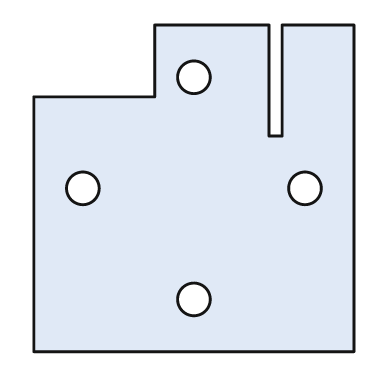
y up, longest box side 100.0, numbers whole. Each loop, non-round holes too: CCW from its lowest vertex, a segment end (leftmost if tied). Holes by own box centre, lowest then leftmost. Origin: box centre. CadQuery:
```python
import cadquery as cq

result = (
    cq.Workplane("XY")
    .moveTo(-49.0, -50.0)
    .lineTo(49.0, -50.0)
    .lineTo(49.0, 50.0)
    .lineTo(27.0, 50.0)
    .lineTo(27.0, 16.0)
    .lineTo(23.0, 16.0)
    .lineTo(23.0, 50.0)
    .lineTo(-12.0, 50.0)
    .lineTo(-12.0, 28.0)
    .lineTo(-49.0, 28.0)
    .close()
    .moveTo(0.0, -34.0)
    .circle(5.0)
    .moveTo(-34.0, 0.0)
    .circle(5.0)
    .moveTo(34.0, 0.0)
    .circle(5.0)
    .moveTo(0.0, 34.0)
    .circle(5.0)
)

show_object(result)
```